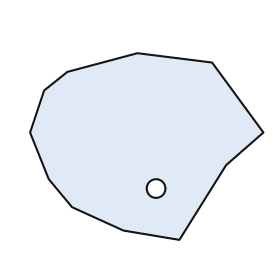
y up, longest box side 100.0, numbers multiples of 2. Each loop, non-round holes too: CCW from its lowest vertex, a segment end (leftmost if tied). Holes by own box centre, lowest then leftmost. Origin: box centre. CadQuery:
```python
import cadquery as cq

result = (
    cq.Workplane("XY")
    .moveTo(14.0, -40.0)
    .lineTo(34.0, -8.0)
    .lineTo(50.0, 6.0)
    .lineTo(28.0, 36.0)
    .lineTo(-4.0, 40.0)
    .lineTo(-34.0, 32.0)
    .lineTo(-44.0, 24.0)
    .lineTo(-50.0, 6.0)
    .lineTo(-42.0, -14.0)
    .lineTo(-32.0, -26.0)
    .lineTo(-10.0, -36.0)
    .close()
    .moveTo(4.0, -18.0)
    .circle(4.0)
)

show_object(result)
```